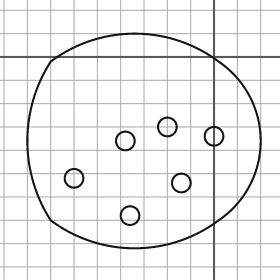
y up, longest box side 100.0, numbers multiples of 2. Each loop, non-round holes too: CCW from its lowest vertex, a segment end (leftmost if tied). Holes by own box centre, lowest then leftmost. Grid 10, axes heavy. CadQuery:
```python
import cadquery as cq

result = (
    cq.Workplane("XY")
    .moveTo(-70.0, -70.0)
    .threePointArc((-34.0, -82.0), (2.0, -70.0))
    .threePointArc((20.0, -36.0), (2.0, -2.0))
    .threePointArc((-34.0, 10.0), (-70.0, -2.0))
    .threePointArc((-80.0, -36.0), (-70.0, -70.0))
    .close()
    .moveTo(-36.0, -68.0)
    .circle(4.0)
    .moveTo(-14.0, -54.0)
    .circle(4.0)
    .moveTo(-60.0, -52.0)
    .circle(4.0)
    .moveTo(-38.0, -36.0)
    .circle(4.0)
    .moveTo(0.0, -34.0)
    .circle(4.0)
    .moveTo(-20.0, -30.0)
    .circle(4.0)
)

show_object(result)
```